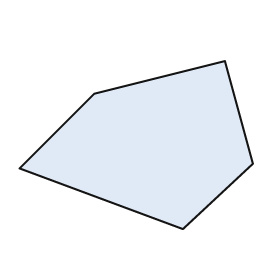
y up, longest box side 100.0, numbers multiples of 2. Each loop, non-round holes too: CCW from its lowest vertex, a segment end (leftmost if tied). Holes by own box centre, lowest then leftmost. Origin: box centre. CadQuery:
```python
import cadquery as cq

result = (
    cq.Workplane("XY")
    .moveTo(20.0, -36.0)
    .lineTo(50.0, -8.0)
    .lineTo(38.0, 36.0)
    .lineTo(-18.0, 22.0)
    .lineTo(-50.0, -10.0)
    .close()
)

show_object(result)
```